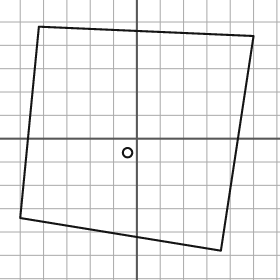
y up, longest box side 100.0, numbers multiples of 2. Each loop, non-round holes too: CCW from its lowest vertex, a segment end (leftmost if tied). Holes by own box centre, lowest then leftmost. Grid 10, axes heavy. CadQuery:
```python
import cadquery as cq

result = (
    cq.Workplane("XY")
    .moveTo(36.0, -48.0)
    .lineTo(50.0, 44.0)
    .lineTo(-42.0, 48.0)
    .lineTo(-50.0, -34.0)
    .close()
    .moveTo(-4.0, -6.0)
    .circle(2.0)
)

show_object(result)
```